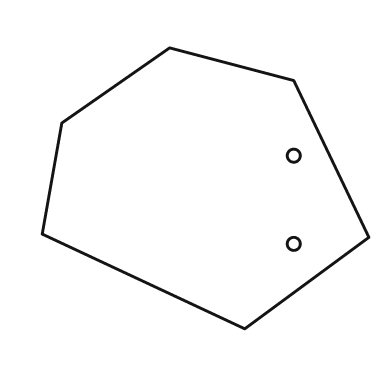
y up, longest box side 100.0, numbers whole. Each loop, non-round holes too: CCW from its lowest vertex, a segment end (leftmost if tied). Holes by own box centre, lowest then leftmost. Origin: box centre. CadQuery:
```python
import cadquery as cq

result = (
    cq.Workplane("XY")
    .moveTo(12.0, -43.0)
    .lineTo(50.0, -15.0)
    .lineTo(27.0, 33.0)
    .lineTo(-11.0, 43.0)
    .lineTo(-44.0, 20.0)
    .lineTo(-50.0, -14.0)
    .close()
    .moveTo(27.0, -17.0)
    .circle(2.0)
    .moveTo(27.0, 10.0)
    .circle(2.0)
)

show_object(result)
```